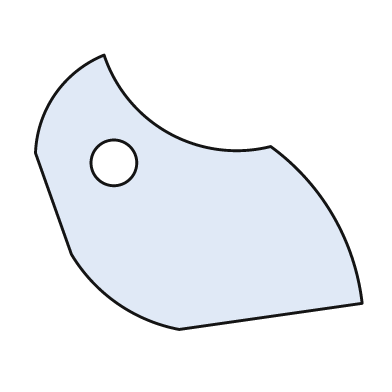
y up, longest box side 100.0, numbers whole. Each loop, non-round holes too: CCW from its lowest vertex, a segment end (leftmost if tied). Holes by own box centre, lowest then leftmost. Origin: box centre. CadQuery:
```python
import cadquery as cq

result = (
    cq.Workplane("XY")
    .moveTo(-6.0, -42.0)
    .lineTo(50.0, -34.0)
    .threePointArc((41.0, -7.0), (22.0, 14.0))
    .threePointArc((-9.0, 18.0), (-29.0, 42.0))
    .threePointArc((-44.0, 30.0), (-50.0, 12.0))
    .lineTo(-39.0, -19.0)
    .threePointArc((-25.0, -34.0), (-6.0, -42.0))
    .close()
    .moveTo(-26.0, 9.0)
    .circle(7.0)
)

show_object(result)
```